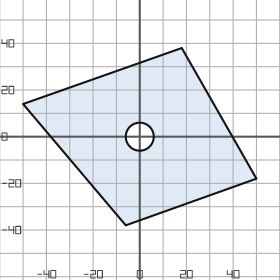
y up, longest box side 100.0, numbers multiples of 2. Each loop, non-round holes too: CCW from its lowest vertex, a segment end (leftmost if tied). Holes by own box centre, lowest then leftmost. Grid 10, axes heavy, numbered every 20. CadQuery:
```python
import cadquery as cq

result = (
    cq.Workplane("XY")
    .moveTo(-6.0, -38.0)
    .lineTo(50.0, -18.0)
    .lineTo(18.0, 38.0)
    .lineTo(-50.0, 14.0)
    .close()
    .moveTo(0.0, 0.0)
    .circle(6.0)
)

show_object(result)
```